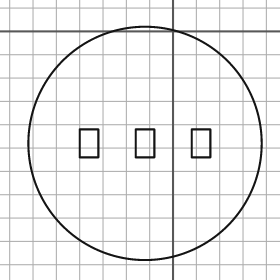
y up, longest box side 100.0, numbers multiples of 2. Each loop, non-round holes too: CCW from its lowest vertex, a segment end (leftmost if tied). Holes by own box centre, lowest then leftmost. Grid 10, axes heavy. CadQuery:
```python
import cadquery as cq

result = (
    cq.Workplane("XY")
    .moveTo(-12.0, -48.0)
    .circle(50.0)
    .moveTo(-40.0, -54.0)
    .lineTo(-32.0, -54.0)
    .lineTo(-32.0, -42.0)
    .lineTo(-40.0, -42.0)
    .close()
    .moveTo(-16.0, -54.0)
    .lineTo(-8.0, -54.0)
    .lineTo(-8.0, -42.0)
    .lineTo(-16.0, -42.0)
    .close()
    .moveTo(8.0, -54.0)
    .lineTo(16.0, -54.0)
    .lineTo(16.0, -42.0)
    .lineTo(8.0, -42.0)
    .close()
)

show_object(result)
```